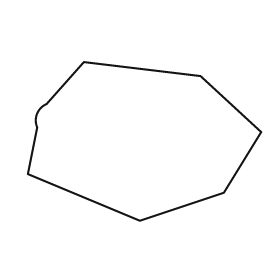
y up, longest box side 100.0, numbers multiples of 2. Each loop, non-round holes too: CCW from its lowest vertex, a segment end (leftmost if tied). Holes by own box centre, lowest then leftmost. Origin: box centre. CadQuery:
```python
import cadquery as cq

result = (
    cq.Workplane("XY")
    .moveTo(-2.0, -34.0)
    .lineTo(34.0, -22.0)
    .lineTo(50.0, 4.0)
    .lineTo(24.0, 28.0)
    .lineTo(-26.0, 34.0)
    .lineTo(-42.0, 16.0)
    .threePointArc((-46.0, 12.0), (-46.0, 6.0))
    .lineTo(-50.0, -14.0)
    .close()
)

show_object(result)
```